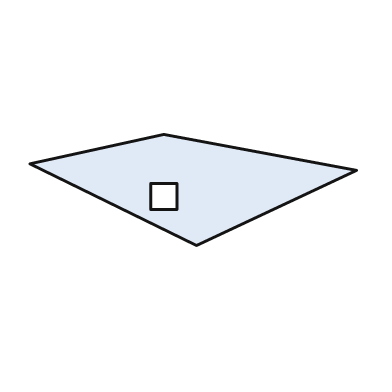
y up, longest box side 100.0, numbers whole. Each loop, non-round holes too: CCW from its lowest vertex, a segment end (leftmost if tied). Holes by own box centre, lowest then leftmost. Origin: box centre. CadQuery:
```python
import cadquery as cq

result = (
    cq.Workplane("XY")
    .moveTo(1.0, -17.0)
    .lineTo(50.0, 6.0)
    .lineTo(-9.0, 17.0)
    .lineTo(-50.0, 8.0)
    .close()
    .moveTo(-13.0, -6.0)
    .lineTo(-5.0, -6.0)
    .lineTo(-5.0, 2.0)
    .lineTo(-13.0, 2.0)
    .close()
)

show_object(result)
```